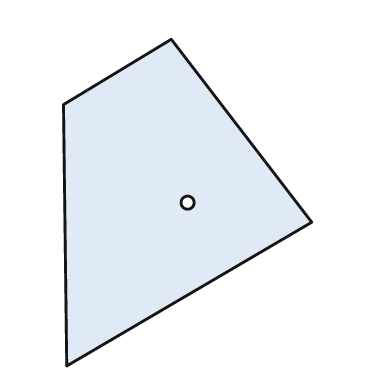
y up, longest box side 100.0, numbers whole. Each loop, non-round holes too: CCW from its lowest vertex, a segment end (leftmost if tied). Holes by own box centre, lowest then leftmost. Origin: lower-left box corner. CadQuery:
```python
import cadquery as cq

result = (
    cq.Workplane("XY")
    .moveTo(1.0, 0.0)
    .lineTo(76.0, 44.0)
    .lineTo(33.0, 100.0)
    .lineTo(0.0, 80.0)
    .close()
    .moveTo(38.0, 50.0)
    .circle(2.0)
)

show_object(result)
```